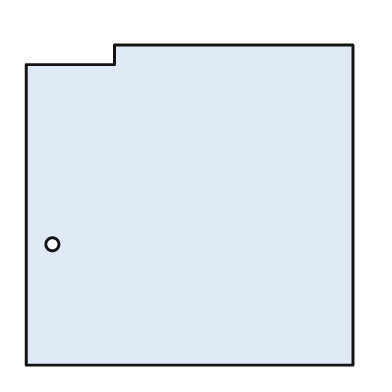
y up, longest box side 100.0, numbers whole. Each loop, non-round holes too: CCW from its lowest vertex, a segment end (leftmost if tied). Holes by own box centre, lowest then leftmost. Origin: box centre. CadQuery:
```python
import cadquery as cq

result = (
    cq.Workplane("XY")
    .moveTo(-50.0, -49.0)
    .lineTo(50.0, -49.0)
    .lineTo(50.0, 49.0)
    .lineTo(-23.0, 49.0)
    .lineTo(-23.0, 43.0)
    .lineTo(-50.0, 43.0)
    .close()
    .moveTo(-42.0, -12.0)
    .circle(2.0)
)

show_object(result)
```